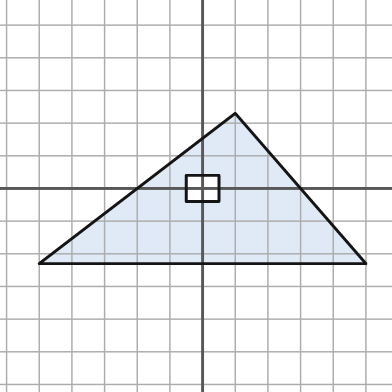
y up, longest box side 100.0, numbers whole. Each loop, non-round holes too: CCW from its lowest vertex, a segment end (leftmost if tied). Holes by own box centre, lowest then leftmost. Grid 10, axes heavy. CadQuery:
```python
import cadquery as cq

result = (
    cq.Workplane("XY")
    .moveTo(-50.0, -23.0)
    .lineTo(50.0, -23.0)
    .lineTo(10.0, 23.0)
    .close()
    .moveTo(-5.0, -4.0)
    .lineTo(5.0, -4.0)
    .lineTo(5.0, 4.0)
    .lineTo(-5.0, 4.0)
    .close()
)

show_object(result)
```